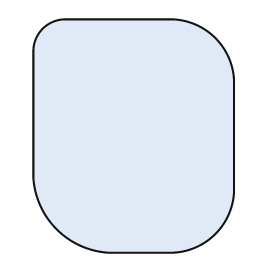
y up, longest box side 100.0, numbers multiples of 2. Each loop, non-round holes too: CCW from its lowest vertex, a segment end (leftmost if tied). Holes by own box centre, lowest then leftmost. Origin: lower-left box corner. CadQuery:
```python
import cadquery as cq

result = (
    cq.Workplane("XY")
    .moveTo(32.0, 0.0)
    .lineTo(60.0, 0.0)
    .threePointArc((78.0, 8.0), (86.0, 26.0))
    .lineTo(86.0, 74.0)
    .threePointArc((78.0, 92.0), (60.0, 100.0))
    .lineTo(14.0, 100.0)
    .threePointArc((4.0, 96.0), (0.0, 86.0))
    .lineTo(0.0, 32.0)
    .threePointArc((10.0, 10.0), (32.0, 0.0))
    .close()
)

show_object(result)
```